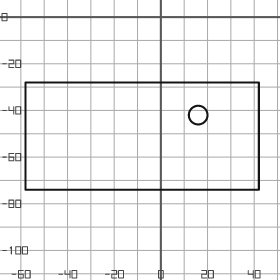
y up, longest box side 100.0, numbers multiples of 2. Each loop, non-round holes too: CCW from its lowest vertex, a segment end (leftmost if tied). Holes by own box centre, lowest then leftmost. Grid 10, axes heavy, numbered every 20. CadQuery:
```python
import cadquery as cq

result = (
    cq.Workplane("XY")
    .moveTo(-58.0, -74.0)
    .lineTo(42.0, -74.0)
    .lineTo(42.0, -28.0)
    .lineTo(-58.0, -28.0)
    .close()
    .moveTo(16.0, -42.0)
    .circle(4.0)
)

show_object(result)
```